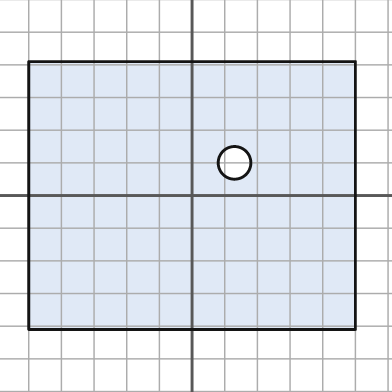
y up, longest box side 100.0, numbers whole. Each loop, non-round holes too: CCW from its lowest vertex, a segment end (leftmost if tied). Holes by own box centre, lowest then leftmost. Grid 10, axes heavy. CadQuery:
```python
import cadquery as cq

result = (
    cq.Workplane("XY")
    .moveTo(-50.0, -41.0)
    .lineTo(50.0, -41.0)
    .lineTo(50.0, 41.0)
    .lineTo(-50.0, 41.0)
    .close()
    .moveTo(13.0, 10.0)
    .circle(5.0)
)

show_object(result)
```